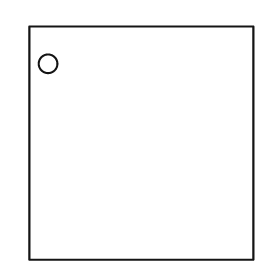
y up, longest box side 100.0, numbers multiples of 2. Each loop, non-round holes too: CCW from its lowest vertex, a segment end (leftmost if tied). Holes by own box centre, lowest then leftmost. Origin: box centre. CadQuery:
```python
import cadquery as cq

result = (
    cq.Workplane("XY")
    .moveTo(-48.0, -50.0)
    .lineTo(48.0, -50.0)
    .lineTo(48.0, 50.0)
    .lineTo(-48.0, 50.0)
    .close()
    .moveTo(-40.0, 34.0)
    .circle(4.0)
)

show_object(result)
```